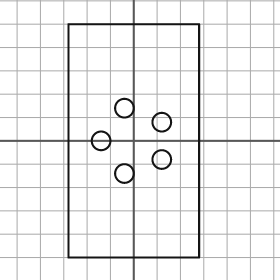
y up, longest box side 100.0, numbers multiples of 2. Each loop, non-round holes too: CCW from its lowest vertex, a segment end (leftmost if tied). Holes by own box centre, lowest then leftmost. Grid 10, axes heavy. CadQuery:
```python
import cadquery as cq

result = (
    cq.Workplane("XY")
    .moveTo(-28.0, -50.0)
    .lineTo(28.0, -50.0)
    .lineTo(28.0, 50.0)
    .lineTo(-28.0, 50.0)
    .close()
    .moveTo(-4.0, -14.0)
    .circle(4.0)
    .moveTo(12.0, -8.0)
    .circle(4.0)
    .moveTo(-14.0, 0.0)
    .circle(4.0)
    .moveTo(12.0, 8.0)
    .circle(4.0)
    .moveTo(-4.0, 14.0)
    .circle(4.0)
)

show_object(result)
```